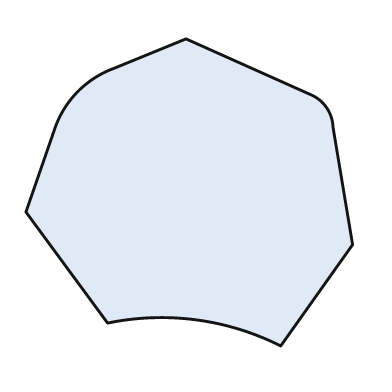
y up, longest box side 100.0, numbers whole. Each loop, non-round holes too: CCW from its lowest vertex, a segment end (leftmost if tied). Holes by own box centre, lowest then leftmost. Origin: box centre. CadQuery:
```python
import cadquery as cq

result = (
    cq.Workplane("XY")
    .moveTo(28.0, -47.0)
    .lineTo(50.0, -16.0)
    .lineTo(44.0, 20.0)
    .threePointArc((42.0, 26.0), (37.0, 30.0))
    .lineTo(-1.0, 47.0)
    .lineTo(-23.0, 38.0)
    .threePointArc((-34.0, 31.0), (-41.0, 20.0))
    .lineTo(-50.0, -6.0)
    .lineTo(-25.0, -40.0)
    .threePointArc((2.0, -39.0), (28.0, -47.0))
    .close()
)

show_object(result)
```